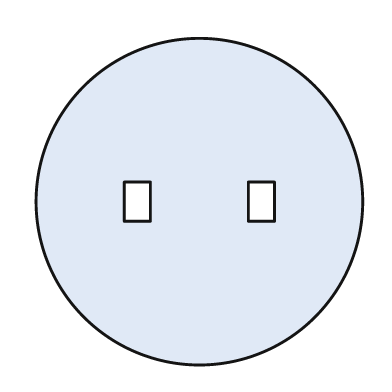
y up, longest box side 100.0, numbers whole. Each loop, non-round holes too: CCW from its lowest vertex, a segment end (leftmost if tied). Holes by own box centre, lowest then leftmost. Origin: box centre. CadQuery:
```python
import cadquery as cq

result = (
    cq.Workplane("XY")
    .moveTo(0.0, 0.0)
    .circle(50.0)
    .moveTo(-23.0, -6.0)
    .lineTo(-15.0, -6.0)
    .lineTo(-15.0, 6.0)
    .lineTo(-23.0, 6.0)
    .close()
    .moveTo(15.0, -6.0)
    .lineTo(23.0, -6.0)
    .lineTo(23.0, 6.0)
    .lineTo(15.0, 6.0)
    .close()
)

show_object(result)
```